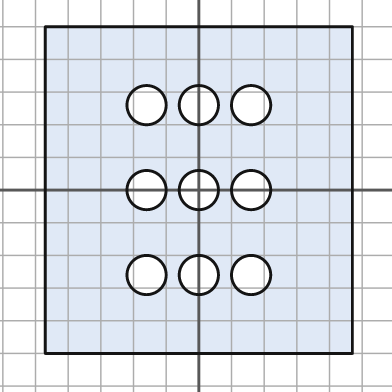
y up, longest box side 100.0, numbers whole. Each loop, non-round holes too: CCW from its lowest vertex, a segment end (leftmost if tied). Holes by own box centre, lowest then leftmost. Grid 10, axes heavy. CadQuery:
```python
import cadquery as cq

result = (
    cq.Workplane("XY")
    .moveTo(-47.0, -50.0)
    .lineTo(47.0, -50.0)
    .lineTo(47.0, 50.0)
    .lineTo(-47.0, 50.0)
    .close()
    .moveTo(-16.0, -26.0)
    .circle(6.0)
    .moveTo(0.0, -26.0)
    .circle(6.0)
    .moveTo(16.0, -26.0)
    .circle(6.0)
    .moveTo(-16.0, 0.0)
    .circle(6.0)
    .moveTo(0.0, 0.0)
    .circle(6.0)
    .moveTo(16.0, 0.0)
    .circle(6.0)
    .moveTo(-16.0, 26.0)
    .circle(6.0)
    .moveTo(0.0, 26.0)
    .circle(6.0)
    .moveTo(16.0, 26.0)
    .circle(6.0)
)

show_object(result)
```